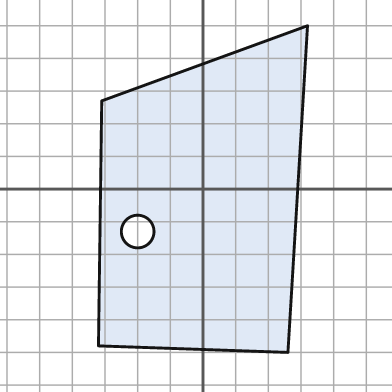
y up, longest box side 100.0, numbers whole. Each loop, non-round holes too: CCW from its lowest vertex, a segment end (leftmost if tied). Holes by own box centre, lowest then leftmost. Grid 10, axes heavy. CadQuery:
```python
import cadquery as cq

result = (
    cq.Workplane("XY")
    .moveTo(26.0, -50.0)
    .lineTo(32.0, 50.0)
    .lineTo(-31.0, 27.0)
    .lineTo(-32.0, -48.0)
    .close()
    .moveTo(-20.0, -13.0)
    .circle(5.0)
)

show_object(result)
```